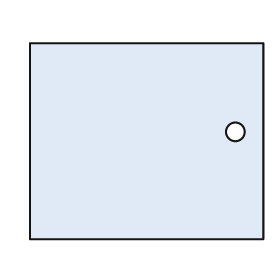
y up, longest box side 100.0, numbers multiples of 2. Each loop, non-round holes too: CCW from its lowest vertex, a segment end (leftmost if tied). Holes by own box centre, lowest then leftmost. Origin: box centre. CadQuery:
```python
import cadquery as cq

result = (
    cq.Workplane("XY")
    .moveTo(-50.0, -42.0)
    .lineTo(50.0, -42.0)
    .lineTo(50.0, 42.0)
    .lineTo(-50.0, 42.0)
    .close()
    .moveTo(38.0, 4.0)
    .circle(4.0)
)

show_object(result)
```